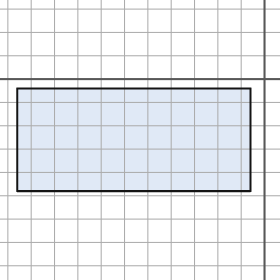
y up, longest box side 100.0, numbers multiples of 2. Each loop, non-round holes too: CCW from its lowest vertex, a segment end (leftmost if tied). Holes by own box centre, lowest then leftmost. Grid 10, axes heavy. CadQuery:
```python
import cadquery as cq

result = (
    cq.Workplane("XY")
    .moveTo(-106.0, -48.0)
    .lineTo(-6.0, -48.0)
    .lineTo(-6.0, -4.0)
    .lineTo(-106.0, -4.0)
    .close()
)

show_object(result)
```